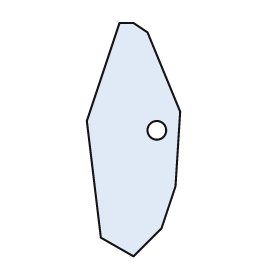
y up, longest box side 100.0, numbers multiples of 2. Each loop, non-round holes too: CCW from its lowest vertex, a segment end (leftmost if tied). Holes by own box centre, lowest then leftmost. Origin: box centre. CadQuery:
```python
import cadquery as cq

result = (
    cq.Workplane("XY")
    .moveTo(0.0, -50.0)
    .lineTo(12.0, -38.0)
    .lineTo(18.0, -20.0)
    .lineTo(20.0, 12.0)
    .lineTo(6.0, 46.0)
    .lineTo(0.0, 50.0)
    .lineTo(-6.0, 50.0)
    .lineTo(-20.0, 8.0)
    .lineTo(-14.0, -42.0)
    .close()
    .moveTo(10.0, 4.0)
    .circle(4.0)
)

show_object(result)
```